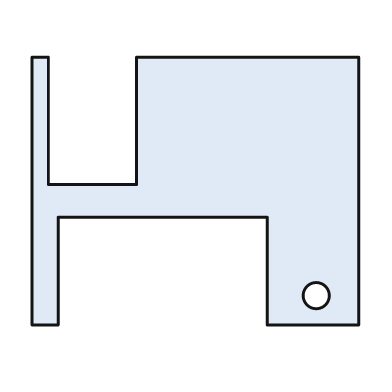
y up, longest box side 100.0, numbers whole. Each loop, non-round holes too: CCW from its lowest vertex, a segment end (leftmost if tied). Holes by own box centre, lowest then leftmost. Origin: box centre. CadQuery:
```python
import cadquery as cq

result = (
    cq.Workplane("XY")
    .moveTo(-50.0, -41.0)
    .lineTo(-42.0, -41.0)
    .lineTo(-42.0, -8.0)
    .lineTo(22.0, -8.0)
    .lineTo(22.0, -41.0)
    .lineTo(50.0, -41.0)
    .lineTo(50.0, 41.0)
    .lineTo(-18.0, 41.0)
    .lineTo(-18.0, 2.0)
    .lineTo(-45.0, 2.0)
    .lineTo(-45.0, 41.0)
    .lineTo(-50.0, 41.0)
    .close()
    .moveTo(37.0, -32.0)
    .circle(4.0)
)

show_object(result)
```